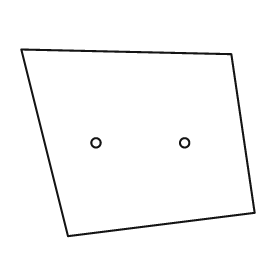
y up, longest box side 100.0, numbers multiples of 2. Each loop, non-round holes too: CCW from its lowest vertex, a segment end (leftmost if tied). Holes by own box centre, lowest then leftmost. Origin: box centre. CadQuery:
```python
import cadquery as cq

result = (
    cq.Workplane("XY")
    .moveTo(-30.0, -40.0)
    .lineTo(50.0, -30.0)
    .lineTo(40.0, 38.0)
    .lineTo(-50.0, 40.0)
    .close()
    .moveTo(-18.0, 0.0)
    .circle(2.0)
    .moveTo(20.0, 0.0)
    .circle(2.0)
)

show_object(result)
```